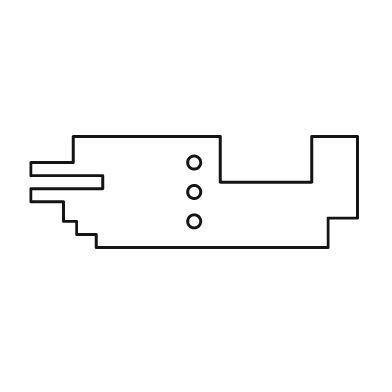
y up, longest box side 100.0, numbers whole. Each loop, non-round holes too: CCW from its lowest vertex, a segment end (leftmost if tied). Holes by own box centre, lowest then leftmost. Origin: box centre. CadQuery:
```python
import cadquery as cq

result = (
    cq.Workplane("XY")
    .moveTo(-30.0, -17.0)
    .lineTo(41.0, -17.0)
    .lineTo(41.0, -8.0)
    .lineTo(50.0, -8.0)
    .lineTo(50.0, 17.0)
    .lineTo(36.0, 17.0)
    .lineTo(36.0, 3.0)
    .lineTo(8.0, 3.0)
    .lineTo(8.0, 17.0)
    .lineTo(-37.0, 17.0)
    .lineTo(-37.0, 9.0)
    .lineTo(-50.0, 9.0)
    .lineTo(-50.0, 5.0)
    .lineTo(-28.0, 5.0)
    .lineTo(-28.0, 1.0)
    .lineTo(-50.0, 1.0)
    .lineTo(-50.0, -3.0)
    .lineTo(-40.0, -3.0)
    .lineTo(-40.0, -9.0)
    .lineTo(-36.0, -9.0)
    .lineTo(-36.0, -13.0)
    .lineTo(-30.0, -13.0)
    .close()
    .moveTo(0.0, -9.0)
    .circle(2.0)
    .moveTo(0.0, 0.0)
    .circle(2.0)
    .moveTo(0.0, 9.0)
    .circle(2.0)
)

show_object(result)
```